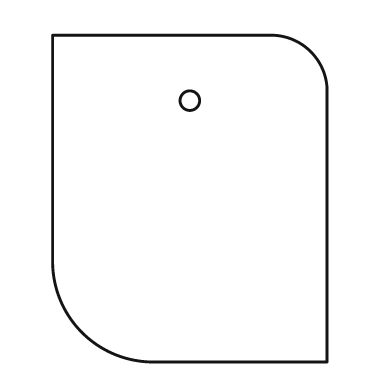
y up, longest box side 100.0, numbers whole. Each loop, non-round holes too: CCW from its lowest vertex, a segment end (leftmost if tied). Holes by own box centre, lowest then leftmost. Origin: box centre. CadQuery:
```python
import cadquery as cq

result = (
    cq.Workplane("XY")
    .moveTo(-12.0, -50.0)
    .lineTo(42.0, -50.0)
    .lineTo(42.0, 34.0)
    .threePointArc((37.0, 45.0), (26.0, 50.0))
    .lineTo(-42.0, 50.0)
    .lineTo(-42.0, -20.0)
    .threePointArc((-33.0, -41.0), (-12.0, -50.0))
    .close()
    .moveTo(0.0, 30.0)
    .circle(3.0)
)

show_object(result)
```